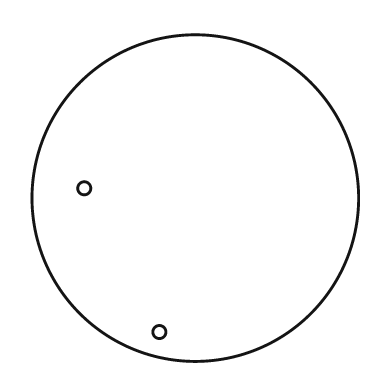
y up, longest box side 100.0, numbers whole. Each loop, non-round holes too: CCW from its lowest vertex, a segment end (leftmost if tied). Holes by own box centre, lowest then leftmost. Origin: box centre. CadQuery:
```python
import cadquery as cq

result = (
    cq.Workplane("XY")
    .moveTo(0.0, 0.0)
    .circle(50.0)
    .moveTo(-11.0, -41.0)
    .circle(2.0)
    .moveTo(-34.0, 3.0)
    .circle(2.0)
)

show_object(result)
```